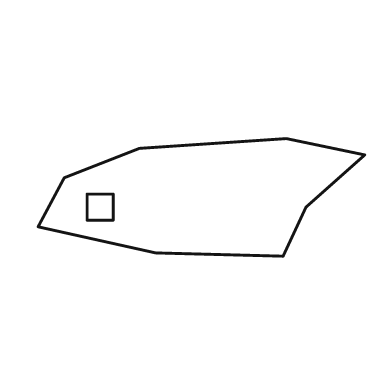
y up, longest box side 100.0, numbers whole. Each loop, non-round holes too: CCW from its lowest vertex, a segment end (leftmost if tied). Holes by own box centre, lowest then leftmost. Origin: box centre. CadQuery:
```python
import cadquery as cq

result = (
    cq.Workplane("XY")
    .moveTo(25.0, -18.0)
    .lineTo(32.0, -3.0)
    .lineTo(50.0, 13.0)
    .lineTo(26.0, 18.0)
    .lineTo(-19.0, 15.0)
    .lineTo(-42.0, 6.0)
    .lineTo(-50.0, -9.0)
    .lineTo(-14.0, -17.0)
    .close()
    .moveTo(-35.0, -7.0)
    .lineTo(-27.0, -7.0)
    .lineTo(-27.0, 1.0)
    .lineTo(-35.0, 1.0)
    .close()
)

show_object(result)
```